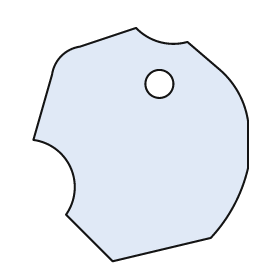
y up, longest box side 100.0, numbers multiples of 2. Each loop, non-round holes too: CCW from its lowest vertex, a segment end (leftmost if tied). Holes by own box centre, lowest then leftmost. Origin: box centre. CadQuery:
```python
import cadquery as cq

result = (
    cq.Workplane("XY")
    .moveTo(-12.0, -50.0)
    .lineTo(30.0, -40.0)
    .threePointArc((40.0, -26.0), (46.0, -10.0))
    .lineTo(46.0, 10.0)
    .threePointArc((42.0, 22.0), (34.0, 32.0))
    .lineTo(20.0, 44.0)
    .threePointArc((8.0, 44.0), (-2.0, 50.0))
    .lineTo(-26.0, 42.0)
    .threePointArc((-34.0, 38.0), (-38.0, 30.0))
    .lineTo(-46.0, 2.0)
    .threePointArc((-30.0, -10.0), (-32.0, -30.0))
    .close()
    .moveTo(8.0, 26.0)
    .circle(6.0)
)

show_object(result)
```